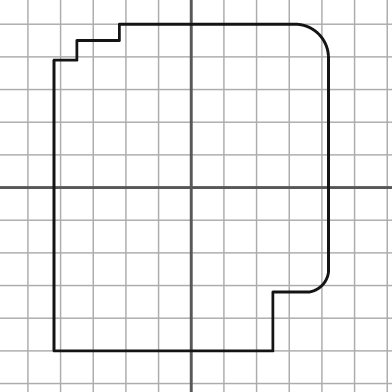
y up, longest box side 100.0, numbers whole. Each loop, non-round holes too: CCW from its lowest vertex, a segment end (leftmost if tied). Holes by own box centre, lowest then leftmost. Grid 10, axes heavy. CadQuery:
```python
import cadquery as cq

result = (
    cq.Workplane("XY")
    .moveTo(-42.0, -50.0)
    .lineTo(25.0, -50.0)
    .lineTo(25.0, -32.0)
    .lineTo(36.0, -32.0)
    .threePointArc((40.0, -30.0), (42.0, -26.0))
    .lineTo(42.0, 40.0)
    .threePointArc((39.0, 47.0), (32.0, 50.0))
    .lineTo(-22.0, 50.0)
    .lineTo(-22.0, 45.0)
    .lineTo(-35.0, 45.0)
    .lineTo(-35.0, 39.0)
    .lineTo(-42.0, 39.0)
    .close()
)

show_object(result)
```